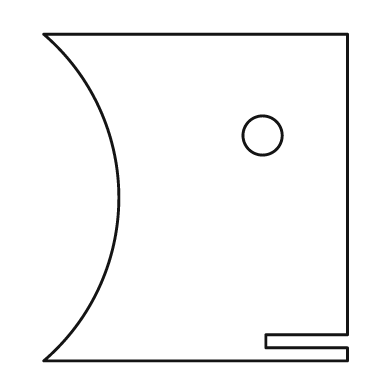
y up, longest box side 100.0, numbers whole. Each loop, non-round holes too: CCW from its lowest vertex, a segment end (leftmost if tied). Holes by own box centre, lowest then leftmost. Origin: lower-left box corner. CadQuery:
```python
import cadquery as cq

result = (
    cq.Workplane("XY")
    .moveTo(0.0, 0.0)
    .lineTo(93.0, 0.0)
    .lineTo(93.0, 4.0)
    .lineTo(68.0, 4.0)
    .lineTo(68.0, 8.0)
    .lineTo(93.0, 8.0)
    .lineTo(93.0, 100.0)
    .lineTo(0.0, 100.0)
    .threePointArc((23.0, 50.0), (0.0, 0.0))
    .close()
    .moveTo(67.0, 69.0)
    .circle(6.0)
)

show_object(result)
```